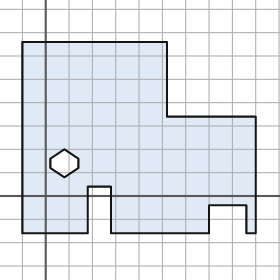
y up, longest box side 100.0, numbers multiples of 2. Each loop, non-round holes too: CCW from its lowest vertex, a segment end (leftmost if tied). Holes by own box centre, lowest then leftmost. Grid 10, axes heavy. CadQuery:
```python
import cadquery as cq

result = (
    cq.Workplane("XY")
    .moveTo(-10.0, -16.0)
    .lineTo(18.0, -16.0)
    .lineTo(18.0, 4.0)
    .lineTo(28.0, 4.0)
    .lineTo(28.0, -16.0)
    .lineTo(70.0, -16.0)
    .lineTo(70.0, -4.0)
    .lineTo(86.0, -4.0)
    .lineTo(86.0, -16.0)
    .lineTo(90.0, -16.0)
    .lineTo(90.0, 34.0)
    .lineTo(52.0, 34.0)
    .lineTo(52.0, 66.0)
    .lineTo(-10.0, 66.0)
    .close()
    .moveTo(8.0, 8.0)
    .lineTo(14.0, 12.0)
    .lineTo(14.0, 16.0)
    .lineTo(8.0, 20.0)
    .lineTo(2.0, 16.0)
    .lineTo(2.0, 12.0)
    .close()
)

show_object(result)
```